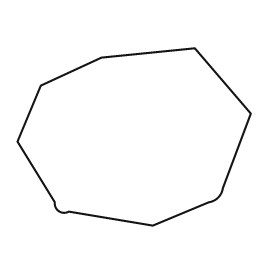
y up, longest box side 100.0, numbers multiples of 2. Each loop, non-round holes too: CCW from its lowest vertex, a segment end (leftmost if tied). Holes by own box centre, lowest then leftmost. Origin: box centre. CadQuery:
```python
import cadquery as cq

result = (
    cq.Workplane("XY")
    .moveTo(8.0, -38.0)
    .lineTo(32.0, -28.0)
    .threePointArc((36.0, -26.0), (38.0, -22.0))
    .lineTo(50.0, 10.0)
    .lineTo(26.0, 38.0)
    .lineTo(-14.0, 34.0)
    .lineTo(-40.0, 22.0)
    .lineTo(-50.0, -2.0)
    .lineTo(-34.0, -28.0)
    .threePointArc((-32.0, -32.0), (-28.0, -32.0))
    .close()
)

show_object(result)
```